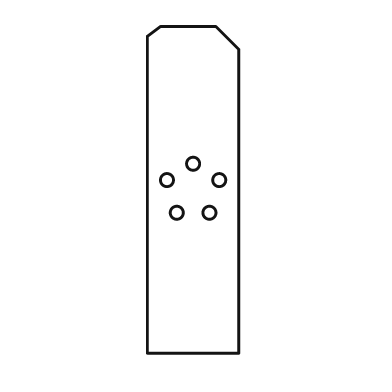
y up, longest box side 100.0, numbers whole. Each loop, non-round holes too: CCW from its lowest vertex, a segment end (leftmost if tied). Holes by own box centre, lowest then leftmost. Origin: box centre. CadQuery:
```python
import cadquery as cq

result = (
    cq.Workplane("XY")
    .moveTo(-14.0, -50.0)
    .lineTo(14.0, -50.0)
    .lineTo(14.0, 43.0)
    .lineTo(7.0, 50.0)
    .lineTo(-10.0, 50.0)
    .lineTo(-14.0, 47.0)
    .close()
    .moveTo(-5.0, -7.0)
    .circle(2.0)
    .moveTo(5.0, -7.0)
    .circle(2.0)
    .moveTo(-8.0, 3.0)
    .circle(2.0)
    .moveTo(8.0, 3.0)
    .circle(2.0)
    .moveTo(0.0, 8.0)
    .circle(2.0)
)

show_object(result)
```